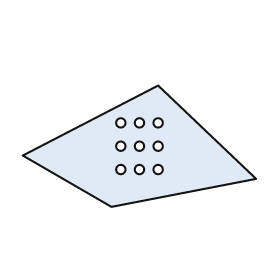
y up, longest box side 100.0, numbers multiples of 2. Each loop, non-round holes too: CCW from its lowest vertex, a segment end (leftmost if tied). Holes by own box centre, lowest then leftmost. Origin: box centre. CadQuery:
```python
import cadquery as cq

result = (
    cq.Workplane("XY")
    .moveTo(-12.0, -26.0)
    .lineTo(50.0, -14.0)
    .lineTo(8.0, 26.0)
    .lineTo(-50.0, -4.0)
    .close()
    .moveTo(-8.0, -10.0)
    .circle(2.0)
    .moveTo(0.0, -10.0)
    .circle(2.0)
    .moveTo(8.0, -10.0)
    .circle(2.0)
    .moveTo(-8.0, 0.0)
    .circle(2.0)
    .moveTo(0.0, 0.0)
    .circle(2.0)
    .moveTo(8.0, 0.0)
    .circle(2.0)
    .moveTo(-8.0, 10.0)
    .circle(2.0)
    .moveTo(0.0, 10.0)
    .circle(2.0)
    .moveTo(8.0, 10.0)
    .circle(2.0)
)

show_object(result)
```